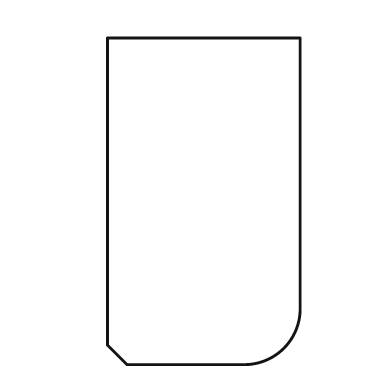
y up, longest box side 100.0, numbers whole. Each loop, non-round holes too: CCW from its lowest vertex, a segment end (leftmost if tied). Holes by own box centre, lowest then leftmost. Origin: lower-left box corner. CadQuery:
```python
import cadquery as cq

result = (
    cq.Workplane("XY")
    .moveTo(6.0, 0.0)
    .lineTo(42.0, 0.0)
    .threePointArc((54.0, 5.0), (59.0, 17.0))
    .lineTo(59.0, 100.0)
    .lineTo(0.0, 100.0)
    .lineTo(0.0, 6.0)
    .close()
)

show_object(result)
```